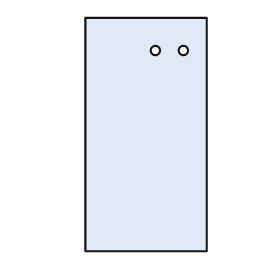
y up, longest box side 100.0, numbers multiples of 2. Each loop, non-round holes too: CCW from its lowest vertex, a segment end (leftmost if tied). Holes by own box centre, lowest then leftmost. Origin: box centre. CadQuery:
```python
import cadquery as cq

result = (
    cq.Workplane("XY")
    .moveTo(-26.0, -50.0)
    .lineTo(26.0, -50.0)
    .lineTo(26.0, 50.0)
    .lineTo(-26.0, 50.0)
    .close()
    .moveTo(4.0, 36.0)
    .circle(2.0)
    .moveTo(16.0, 36.0)
    .circle(2.0)
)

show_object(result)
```